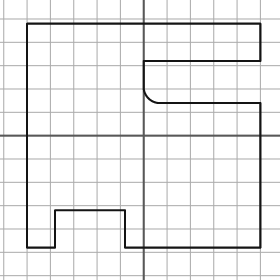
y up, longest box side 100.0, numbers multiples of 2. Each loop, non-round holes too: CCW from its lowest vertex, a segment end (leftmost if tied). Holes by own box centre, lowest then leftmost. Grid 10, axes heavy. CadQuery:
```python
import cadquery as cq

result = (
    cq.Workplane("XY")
    .moveTo(-50.0, -48.0)
    .lineTo(-38.0, -48.0)
    .lineTo(-38.0, -32.0)
    .lineTo(-8.0, -32.0)
    .lineTo(-8.0, -48.0)
    .lineTo(50.0, -48.0)
    .lineTo(50.0, 14.0)
    .lineTo(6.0, 14.0)
    .threePointArc((2.0, 16.0), (0.0, 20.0))
    .lineTo(0.0, 32.0)
    .lineTo(50.0, 32.0)
    .lineTo(50.0, 48.0)
    .lineTo(-50.0, 48.0)
    .close()
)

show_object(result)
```